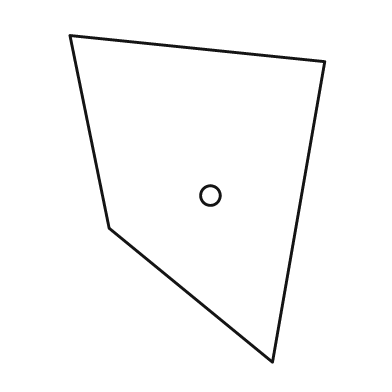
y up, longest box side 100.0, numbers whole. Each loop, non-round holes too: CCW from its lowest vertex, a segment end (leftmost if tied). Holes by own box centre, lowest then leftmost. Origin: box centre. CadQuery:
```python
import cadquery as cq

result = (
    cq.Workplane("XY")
    .moveTo(23.0, -50.0)
    .lineTo(39.0, 42.0)
    .lineTo(-39.0, 50.0)
    .lineTo(-27.0, -9.0)
    .close()
    .moveTo(4.0, 1.0)
    .circle(3.0)
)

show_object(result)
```